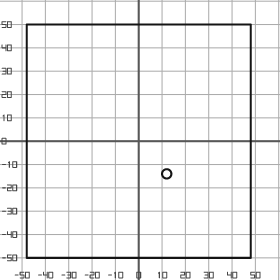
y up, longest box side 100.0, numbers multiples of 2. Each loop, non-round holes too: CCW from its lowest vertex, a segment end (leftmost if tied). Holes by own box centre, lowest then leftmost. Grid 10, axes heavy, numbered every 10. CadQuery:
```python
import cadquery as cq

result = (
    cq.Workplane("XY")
    .moveTo(-48.0, -50.0)
    .lineTo(48.0, -50.0)
    .lineTo(48.0, 50.0)
    .lineTo(-48.0, 50.0)
    .close()
    .moveTo(12.0, -14.0)
    .circle(2.0)
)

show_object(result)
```